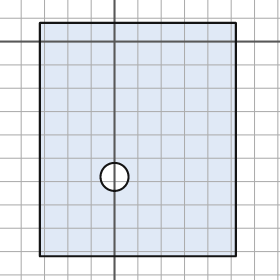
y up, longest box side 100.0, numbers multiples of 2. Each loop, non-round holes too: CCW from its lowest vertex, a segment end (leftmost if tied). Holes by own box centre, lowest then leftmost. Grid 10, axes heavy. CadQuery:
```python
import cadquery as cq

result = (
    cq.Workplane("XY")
    .moveTo(-32.0, -92.0)
    .lineTo(52.0, -92.0)
    .lineTo(52.0, 8.0)
    .lineTo(-32.0, 8.0)
    .close()
    .moveTo(0.0, -58.0)
    .circle(6.0)
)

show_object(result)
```